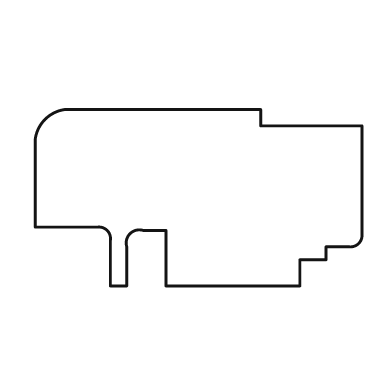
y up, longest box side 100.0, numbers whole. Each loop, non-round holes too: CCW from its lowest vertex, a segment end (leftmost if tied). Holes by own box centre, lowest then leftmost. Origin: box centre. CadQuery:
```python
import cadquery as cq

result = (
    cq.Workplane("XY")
    .moveTo(-27.0, -27.0)
    .lineTo(-22.0, -27.0)
    .lineTo(-22.0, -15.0)
    .threePointArc((-21.0, -11.0), (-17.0, -10.0))
    .lineTo(-10.0, -10.0)
    .lineTo(-10.0, -27.0)
    .lineTo(31.0, -27.0)
    .lineTo(31.0, -19.0)
    .lineTo(39.0, -19.0)
    .lineTo(39.0, -15.0)
    .lineTo(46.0, -15.0)
    .threePointArc((49.0, -14.0), (50.0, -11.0))
    .lineTo(50.0, 22.0)
    .lineTo(19.0, 22.0)
    .lineTo(19.0, 27.0)
    .lineTo(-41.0, 27.0)
    .threePointArc((-47.0, 24.0), (-50.0, 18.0))
    .lineTo(-50.0, -9.0)
    .lineTo(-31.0, -9.0)
    .threePointArc((-28.0, -10.0), (-27.0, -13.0))
    .close()
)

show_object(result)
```